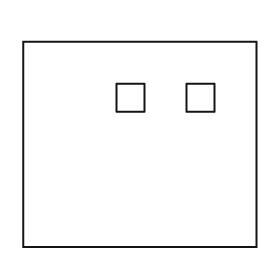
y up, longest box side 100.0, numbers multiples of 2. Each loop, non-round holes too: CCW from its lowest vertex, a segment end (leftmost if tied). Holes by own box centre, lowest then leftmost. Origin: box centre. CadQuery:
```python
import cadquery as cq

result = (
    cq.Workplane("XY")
    .moveTo(-50.0, -44.0)
    .lineTo(50.0, -44.0)
    .lineTo(50.0, 44.0)
    .lineTo(-50.0, 44.0)
    .close()
    .moveTo(-10.0, 14.0)
    .lineTo(2.0, 14.0)
    .lineTo(2.0, 26.0)
    .lineTo(-10.0, 26.0)
    .close()
    .moveTo(20.0, 14.0)
    .lineTo(32.0, 14.0)
    .lineTo(32.0, 26.0)
    .lineTo(20.0, 26.0)
    .close()
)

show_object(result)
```